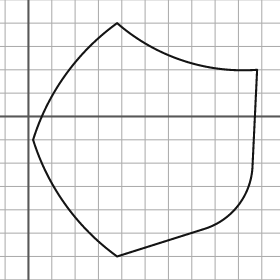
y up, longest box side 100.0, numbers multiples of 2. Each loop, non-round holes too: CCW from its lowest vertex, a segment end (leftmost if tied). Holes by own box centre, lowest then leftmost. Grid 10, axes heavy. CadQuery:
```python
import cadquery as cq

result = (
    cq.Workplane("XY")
    .moveTo(38.0, -60.0)
    .lineTo(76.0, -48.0)
    .threePointArc((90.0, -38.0), (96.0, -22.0))
    .lineTo(98.0, 20.0)
    .threePointArc((66.0, 24.0), (38.0, 40.0))
    .threePointArc((16.0, 18.0), (2.0, -10.0))
    .threePointArc((16.0, -38.0), (38.0, -60.0))
    .close()
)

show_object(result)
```